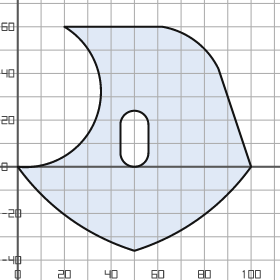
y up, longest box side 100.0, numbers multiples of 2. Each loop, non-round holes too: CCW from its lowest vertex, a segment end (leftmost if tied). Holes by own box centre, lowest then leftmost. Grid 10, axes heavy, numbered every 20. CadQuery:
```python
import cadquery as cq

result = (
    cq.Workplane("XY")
    .moveTo(50.0, -36.0)
    .threePointArc((78.0, -22.0), (100.0, 0.0))
    .lineTo(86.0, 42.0)
    .threePointArc((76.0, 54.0), (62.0, 60.0))
    .lineTo(20.0, 60.0)
    .threePointArc((34.0, 22.0), (0.0, 0.0))
    .threePointArc((22.0, -22.0), (50.0, -36.0))
    .close()
    .moveTo(44.0, 6.0)
    .threePointArc((50.0, 0.0), (56.0, 6.0))
    .lineTo(56.0, 18.0)
    .threePointArc((50.0, 24.0), (44.0, 18.0))
    .close()
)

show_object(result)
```